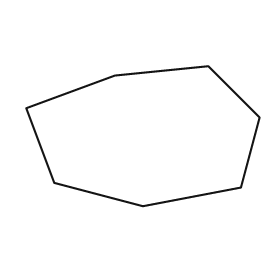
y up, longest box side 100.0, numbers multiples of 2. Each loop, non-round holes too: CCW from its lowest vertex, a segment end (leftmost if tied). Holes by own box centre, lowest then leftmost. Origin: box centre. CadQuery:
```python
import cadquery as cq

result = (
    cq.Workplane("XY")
    .moveTo(0.0, -30.0)
    .lineTo(42.0, -22.0)
    .lineTo(50.0, 8.0)
    .lineTo(28.0, 30.0)
    .lineTo(-12.0, 26.0)
    .lineTo(-50.0, 12.0)
    .lineTo(-38.0, -20.0)
    .close()
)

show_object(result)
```